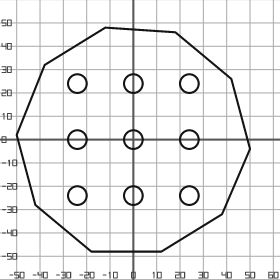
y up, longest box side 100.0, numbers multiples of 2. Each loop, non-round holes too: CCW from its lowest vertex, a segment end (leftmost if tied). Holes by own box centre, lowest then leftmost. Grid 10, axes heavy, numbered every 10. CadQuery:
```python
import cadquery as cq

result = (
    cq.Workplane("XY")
    .moveTo(-18.0, -48.0)
    .lineTo(12.0, -48.0)
    .lineTo(38.0, -32.0)
    .lineTo(50.0, -4.0)
    .lineTo(42.0, 26.0)
    .lineTo(18.0, 46.0)
    .lineTo(-12.0, 48.0)
    .lineTo(-38.0, 32.0)
    .lineTo(-50.0, 2.0)
    .lineTo(-42.0, -28.0)
    .close()
    .moveTo(-24.0, -24.0)
    .circle(4.0)
    .moveTo(0.0, -24.0)
    .circle(4.0)
    .moveTo(24.0, -24.0)
    .circle(4.0)
    .moveTo(-24.0, 0.0)
    .circle(4.0)
    .moveTo(0.0, 0.0)
    .circle(4.0)
    .moveTo(24.0, 0.0)
    .circle(4.0)
    .moveTo(-24.0, 24.0)
    .circle(4.0)
    .moveTo(0.0, 24.0)
    .circle(4.0)
    .moveTo(24.0, 24.0)
    .circle(4.0)
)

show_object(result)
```